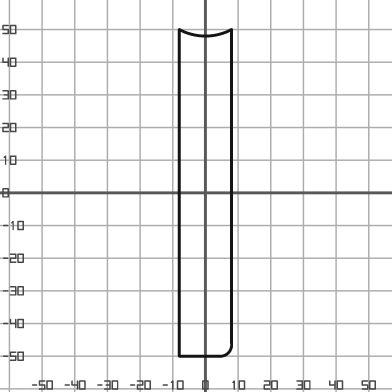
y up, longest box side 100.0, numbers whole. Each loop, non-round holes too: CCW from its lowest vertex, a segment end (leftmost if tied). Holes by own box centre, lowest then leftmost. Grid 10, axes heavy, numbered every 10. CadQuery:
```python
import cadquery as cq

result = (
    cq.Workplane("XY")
    .moveTo(-8.0, -50.0)
    .lineTo(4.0, -50.0)
    .threePointArc((7.0, -49.0), (8.0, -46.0))
    .lineTo(8.0, 50.0)
    .threePointArc((0.0, 48.0), (-8.0, 50.0))
    .close()
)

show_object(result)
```